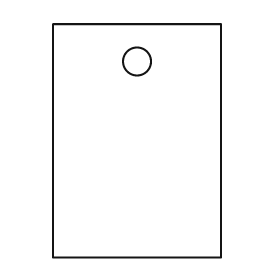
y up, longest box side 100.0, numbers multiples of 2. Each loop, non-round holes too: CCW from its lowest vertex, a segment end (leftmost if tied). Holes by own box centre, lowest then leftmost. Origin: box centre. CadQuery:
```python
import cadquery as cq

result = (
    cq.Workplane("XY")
    .moveTo(-36.0, -50.0)
    .lineTo(36.0, -50.0)
    .lineTo(36.0, 50.0)
    .lineTo(-36.0, 50.0)
    .close()
    .moveTo(0.0, 34.0)
    .circle(6.0)
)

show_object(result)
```